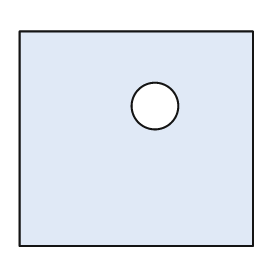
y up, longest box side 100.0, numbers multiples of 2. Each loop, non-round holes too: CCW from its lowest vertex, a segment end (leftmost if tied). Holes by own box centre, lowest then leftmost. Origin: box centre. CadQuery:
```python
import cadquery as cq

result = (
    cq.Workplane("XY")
    .moveTo(-50.0, -46.0)
    .lineTo(50.0, -46.0)
    .lineTo(50.0, 46.0)
    .lineTo(-50.0, 46.0)
    .close()
    .moveTo(8.0, 14.0)
    .circle(10.0)
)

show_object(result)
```